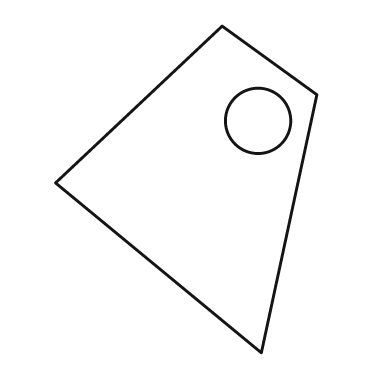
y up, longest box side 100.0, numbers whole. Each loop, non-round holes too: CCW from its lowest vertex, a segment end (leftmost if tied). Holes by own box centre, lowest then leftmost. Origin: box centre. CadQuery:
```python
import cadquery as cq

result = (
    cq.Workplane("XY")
    .moveTo(23.0, -50.0)
    .lineTo(40.0, 29.0)
    .lineTo(11.0, 50.0)
    .lineTo(-40.0, 2.0)
    .close()
    .moveTo(22.0, 21.0)
    .circle(10.0)
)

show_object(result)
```